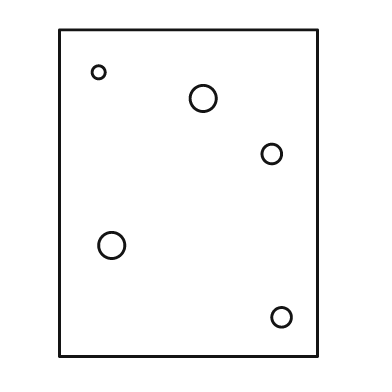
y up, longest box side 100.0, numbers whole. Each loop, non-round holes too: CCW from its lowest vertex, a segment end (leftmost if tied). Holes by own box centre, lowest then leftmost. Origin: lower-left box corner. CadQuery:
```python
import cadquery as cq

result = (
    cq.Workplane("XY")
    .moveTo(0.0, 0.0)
    .lineTo(79.0, 0.0)
    .lineTo(79.0, 100.0)
    .lineTo(0.0, 100.0)
    .close()
    .moveTo(68.0, 12.0)
    .circle(3.0)
    .moveTo(16.0, 34.0)
    .circle(4.0)
    .moveTo(65.0, 62.0)
    .circle(3.0)
    .moveTo(44.0, 79.0)
    .circle(4.0)
    .moveTo(12.0, 87.0)
    .circle(2.0)
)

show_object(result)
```